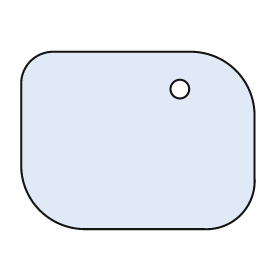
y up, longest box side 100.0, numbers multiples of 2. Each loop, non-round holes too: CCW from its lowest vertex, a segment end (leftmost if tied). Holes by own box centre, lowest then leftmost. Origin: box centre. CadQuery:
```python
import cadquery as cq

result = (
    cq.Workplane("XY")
    .moveTo(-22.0, -38.0)
    .lineTo(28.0, -38.0)
    .threePointArc((44.0, -32.0), (50.0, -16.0))
    .lineTo(50.0, 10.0)
    .threePointArc((42.0, 30.0), (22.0, 38.0))
    .lineTo(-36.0, 38.0)
    .threePointArc((-46.0, 34.0), (-50.0, 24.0))
    .lineTo(-50.0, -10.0)
    .threePointArc((-42.0, -30.0), (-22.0, -38.0))
    .close()
    .moveTo(18.0, 22.0)
    .circle(4.0)
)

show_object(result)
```